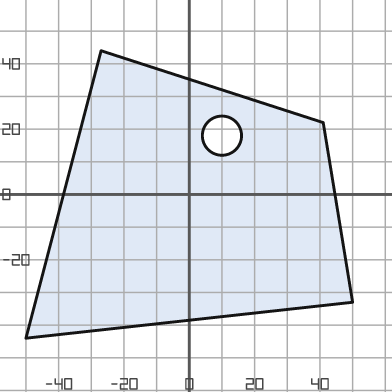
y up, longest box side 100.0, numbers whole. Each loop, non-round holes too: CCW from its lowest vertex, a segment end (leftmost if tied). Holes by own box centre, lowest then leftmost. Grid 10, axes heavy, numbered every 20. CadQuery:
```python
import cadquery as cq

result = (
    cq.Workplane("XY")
    .moveTo(-50.0, -44.0)
    .lineTo(50.0, -33.0)
    .lineTo(41.0, 22.0)
    .lineTo(-27.0, 44.0)
    .close()
    .moveTo(10.0, 18.0)
    .circle(6.0)
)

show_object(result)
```